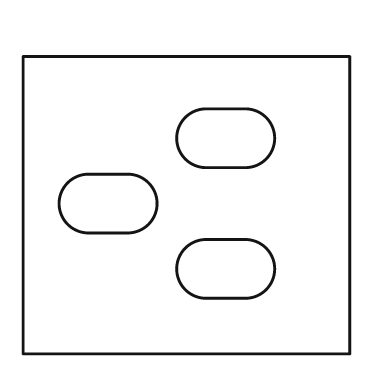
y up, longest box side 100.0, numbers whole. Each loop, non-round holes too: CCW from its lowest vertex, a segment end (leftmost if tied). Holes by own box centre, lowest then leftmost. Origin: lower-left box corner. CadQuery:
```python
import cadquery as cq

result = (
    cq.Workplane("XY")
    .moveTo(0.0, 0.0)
    .lineTo(100.0, 0.0)
    .lineTo(100.0, 91.0)
    .lineTo(0.0, 91.0)
    .close()
    .moveTo(56.0, 17.0)
    .lineTo(68.0, 17.0)
    .threePointArc((77.0, 26.0), (68.0, 35.0))
    .lineTo(56.0, 35.0)
    .threePointArc((47.0, 26.0), (56.0, 17.0))
    .close()
    .moveTo(20.0, 37.0)
    .lineTo(32.0, 37.0)
    .threePointArc((41.0, 46.0), (32.0, 55.0))
    .lineTo(20.0, 55.0)
    .threePointArc((11.0, 46.0), (20.0, 37.0))
    .close()
    .moveTo(56.0, 57.0)
    .lineTo(68.0, 57.0)
    .threePointArc((77.0, 66.0), (68.0, 75.0))
    .lineTo(56.0, 75.0)
    .threePointArc((47.0, 66.0), (56.0, 57.0))
    .close()
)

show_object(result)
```